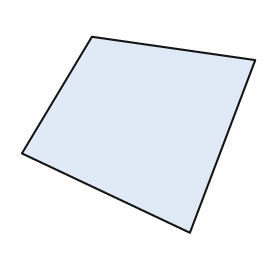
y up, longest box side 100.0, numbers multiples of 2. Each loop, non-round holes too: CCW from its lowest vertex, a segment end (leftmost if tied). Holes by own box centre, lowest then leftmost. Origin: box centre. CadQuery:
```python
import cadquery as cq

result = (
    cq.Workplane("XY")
    .moveTo(22.0, -42.0)
    .lineTo(50.0, 32.0)
    .lineTo(-20.0, 42.0)
    .lineTo(-50.0, -8.0)
    .close()
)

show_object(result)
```